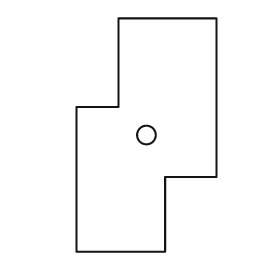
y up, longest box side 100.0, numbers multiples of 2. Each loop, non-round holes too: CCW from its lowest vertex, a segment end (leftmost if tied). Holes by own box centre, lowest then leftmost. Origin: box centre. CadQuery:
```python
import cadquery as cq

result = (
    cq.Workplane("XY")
    .moveTo(-30.0, -50.0)
    .lineTo(8.0, -50.0)
    .lineTo(8.0, -18.0)
    .lineTo(30.0, -18.0)
    .lineTo(30.0, 50.0)
    .lineTo(-12.0, 50.0)
    .lineTo(-12.0, 12.0)
    .lineTo(-30.0, 12.0)
    .close()
    .moveTo(0.0, 0.0)
    .circle(4.0)
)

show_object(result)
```